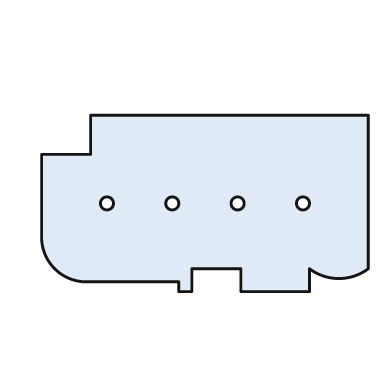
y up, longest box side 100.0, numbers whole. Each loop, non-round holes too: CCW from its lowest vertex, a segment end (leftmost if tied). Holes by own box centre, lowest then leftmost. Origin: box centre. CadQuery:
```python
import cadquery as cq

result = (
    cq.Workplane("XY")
    .moveTo(-8.0, -27.0)
    .lineTo(-4.0, -27.0)
    .lineTo(-4.0, -20.0)
    .lineTo(11.0, -20.0)
    .lineTo(11.0, -27.0)
    .lineTo(32.0, -27.0)
    .lineTo(32.0, -20.0)
    .threePointArc((41.0, -23.0), (50.0, -20.0))
    .lineTo(50.0, 27.0)
    .lineTo(-35.0, 27.0)
    .lineTo(-35.0, 15.0)
    .lineTo(-50.0, 15.0)
    .lineTo(-50.0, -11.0)
    .threePointArc((-46.0, -20.0), (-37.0, -24.0))
    .lineTo(-8.0, -24.0)
    .close()
    .moveTo(-30.0, 0.0)
    .circle(2.0)
    .moveTo(-10.0, 0.0)
    .circle(2.0)
    .moveTo(10.0, 0.0)
    .circle(2.0)
    .moveTo(30.0, 0.0)
    .circle(2.0)
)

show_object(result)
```